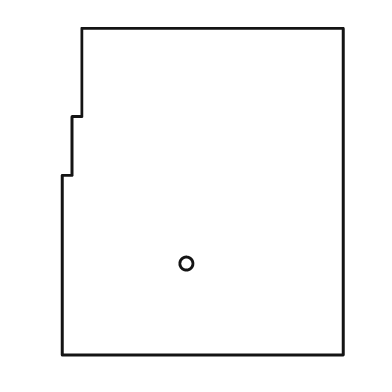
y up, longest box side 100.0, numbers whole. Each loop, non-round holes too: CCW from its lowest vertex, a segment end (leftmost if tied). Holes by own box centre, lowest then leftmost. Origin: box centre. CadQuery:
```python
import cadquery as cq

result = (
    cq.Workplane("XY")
    .moveTo(-43.0, -50.0)
    .lineTo(43.0, -50.0)
    .lineTo(43.0, 50.0)
    .lineTo(-37.0, 50.0)
    .lineTo(-37.0, 23.0)
    .lineTo(-40.0, 23.0)
    .lineTo(-40.0, 5.0)
    .lineTo(-43.0, 5.0)
    .close()
    .moveTo(-5.0, -22.0)
    .circle(2.0)
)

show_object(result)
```